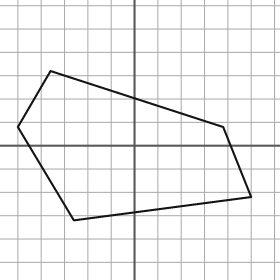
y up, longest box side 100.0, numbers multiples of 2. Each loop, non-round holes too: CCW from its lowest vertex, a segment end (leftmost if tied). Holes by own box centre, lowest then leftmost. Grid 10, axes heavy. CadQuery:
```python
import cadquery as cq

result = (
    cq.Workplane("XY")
    .moveTo(-26.0, -32.0)
    .lineTo(50.0, -22.0)
    .lineTo(38.0, 8.0)
    .lineTo(-36.0, 32.0)
    .lineTo(-50.0, 8.0)
    .close()
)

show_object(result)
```